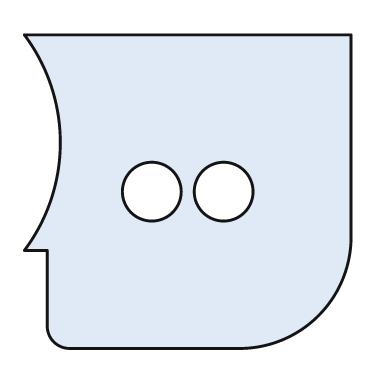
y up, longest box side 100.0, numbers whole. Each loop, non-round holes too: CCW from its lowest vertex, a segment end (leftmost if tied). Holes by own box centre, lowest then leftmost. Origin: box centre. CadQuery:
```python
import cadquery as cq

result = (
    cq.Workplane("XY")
    .moveTo(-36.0, -48.0)
    .lineTo(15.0, -48.0)
    .threePointArc((40.0, -38.0), (50.0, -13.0))
    .lineTo(50.0, 48.0)
    .lineTo(-50.0, 48.0)
    .threePointArc((-39.0, 15.0), (-50.0, -18.0))
    .lineTo(-43.0, -18.0)
    .lineTo(-43.0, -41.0)
    .threePointArc((-41.0, -46.0), (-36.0, -48.0))
    .close()
    .moveTo(-11.0, 0.0)
    .circle(9.0)
    .moveTo(11.0, 0.0)
    .circle(9.0)
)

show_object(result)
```